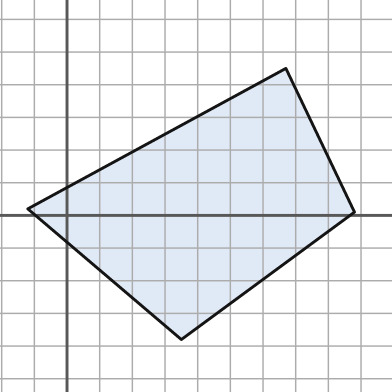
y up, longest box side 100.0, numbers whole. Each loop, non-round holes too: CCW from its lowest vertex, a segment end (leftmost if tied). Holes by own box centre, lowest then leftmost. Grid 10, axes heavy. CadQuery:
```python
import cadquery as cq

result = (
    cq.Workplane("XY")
    .moveTo(35.0, -38.0)
    .lineTo(88.0, 1.0)
    .lineTo(67.0, 45.0)
    .lineTo(-12.0, 2.0)
    .close()
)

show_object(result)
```